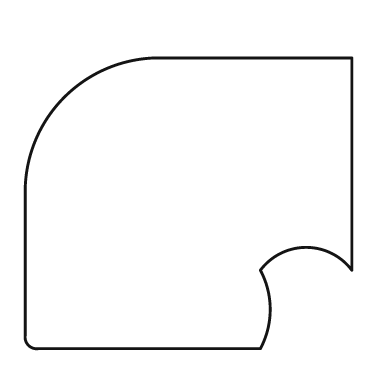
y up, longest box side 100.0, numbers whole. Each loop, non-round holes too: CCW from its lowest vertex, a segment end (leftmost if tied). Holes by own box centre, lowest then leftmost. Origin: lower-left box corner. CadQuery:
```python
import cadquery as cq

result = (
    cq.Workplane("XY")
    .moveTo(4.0, 0.0)
    .lineTo(72.0, 0.0)
    .threePointArc((75.0, 12.0), (72.0, 24.0))
    .threePointArc((86.0, 31.0), (100.0, 24.0))
    .lineTo(100.0, 89.0)
    .lineTo(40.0, 89.0)
    .threePointArc((12.0, 77.0), (0.0, 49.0))
    .lineTo(0.0, 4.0)
    .threePointArc((1.0, 1.0), (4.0, 0.0))
    .close()
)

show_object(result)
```